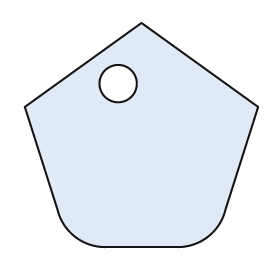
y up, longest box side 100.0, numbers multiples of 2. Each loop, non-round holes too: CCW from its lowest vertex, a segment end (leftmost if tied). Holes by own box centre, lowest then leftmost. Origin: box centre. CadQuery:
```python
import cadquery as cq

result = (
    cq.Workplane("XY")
    .moveTo(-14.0, -48.0)
    .lineTo(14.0, -48.0)
    .threePointArc((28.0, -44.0), (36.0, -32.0))
    .lineTo(50.0, 12.0)
    .lineTo(0.0, 48.0)
    .lineTo(-50.0, 12.0)
    .lineTo(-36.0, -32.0)
    .threePointArc((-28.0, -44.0), (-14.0, -48.0))
    .close()
    .moveTo(-10.0, 22.0)
    .circle(8.0)
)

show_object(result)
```